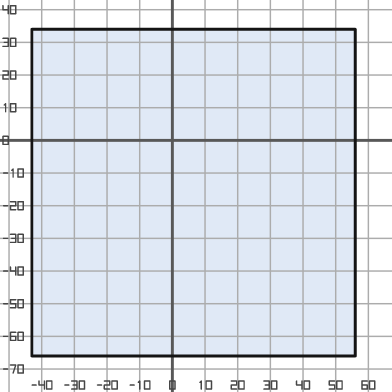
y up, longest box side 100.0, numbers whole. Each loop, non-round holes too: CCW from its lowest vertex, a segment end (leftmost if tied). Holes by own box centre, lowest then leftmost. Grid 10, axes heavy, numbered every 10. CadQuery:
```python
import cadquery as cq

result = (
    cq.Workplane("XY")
    .moveTo(-43.0, -66.0)
    .lineTo(56.0, -66.0)
    .lineTo(56.0, 34.0)
    .lineTo(-43.0, 34.0)
    .close()
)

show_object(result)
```